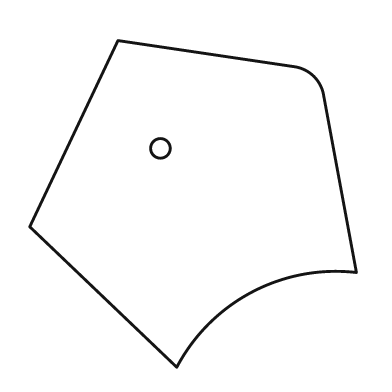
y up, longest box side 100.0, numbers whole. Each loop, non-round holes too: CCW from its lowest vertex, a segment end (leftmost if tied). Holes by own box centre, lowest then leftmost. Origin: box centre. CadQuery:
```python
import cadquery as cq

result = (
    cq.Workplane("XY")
    .moveTo(-5.0, -50.0)
    .threePointArc((18.0, -27.0), (50.0, -21.0))
    .lineTo(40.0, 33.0)
    .threePointArc((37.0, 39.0), (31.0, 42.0))
    .lineTo(-23.0, 50.0)
    .lineTo(-50.0, -7.0)
    .close()
    .moveTo(-10.0, 17.0)
    .circle(3.0)
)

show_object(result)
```